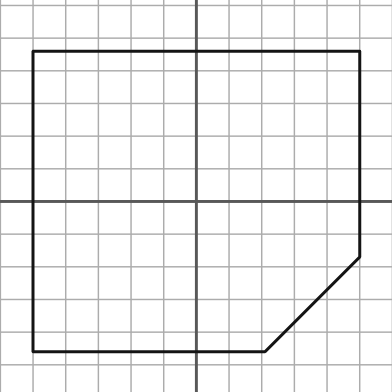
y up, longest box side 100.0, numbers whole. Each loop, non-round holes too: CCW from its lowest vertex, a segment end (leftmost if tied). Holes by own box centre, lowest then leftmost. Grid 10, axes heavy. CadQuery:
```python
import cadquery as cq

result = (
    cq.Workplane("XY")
    .moveTo(-50.0, -46.0)
    .lineTo(21.0, -46.0)
    .lineTo(50.0, -17.0)
    .lineTo(50.0, 46.0)
    .lineTo(-50.0, 46.0)
    .close()
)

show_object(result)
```